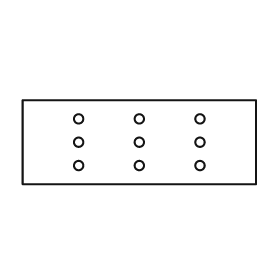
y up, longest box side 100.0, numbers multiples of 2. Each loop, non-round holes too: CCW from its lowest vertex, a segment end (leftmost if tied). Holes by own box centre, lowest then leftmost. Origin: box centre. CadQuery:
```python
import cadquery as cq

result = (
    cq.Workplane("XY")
    .moveTo(-50.0, -18.0)
    .lineTo(50.0, -18.0)
    .lineTo(50.0, 18.0)
    .lineTo(-50.0, 18.0)
    .close()
    .moveTo(-26.0, -10.0)
    .circle(2.0)
    .moveTo(0.0, -10.0)
    .circle(2.0)
    .moveTo(26.0, -10.0)
    .circle(2.0)
    .moveTo(-26.0, 0.0)
    .circle(2.0)
    .moveTo(0.0, 0.0)
    .circle(2.0)
    .moveTo(26.0, 0.0)
    .circle(2.0)
    .moveTo(-26.0, 10.0)
    .circle(2.0)
    .moveTo(0.0, 10.0)
    .circle(2.0)
    .moveTo(26.0, 10.0)
    .circle(2.0)
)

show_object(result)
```